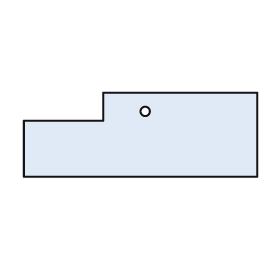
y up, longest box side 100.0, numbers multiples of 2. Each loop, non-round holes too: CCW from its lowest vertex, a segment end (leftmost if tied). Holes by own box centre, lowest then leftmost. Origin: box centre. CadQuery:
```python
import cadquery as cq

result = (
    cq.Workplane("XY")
    .moveTo(-50.0, -18.0)
    .lineTo(50.0, -18.0)
    .lineTo(50.0, 18.0)
    .lineTo(-16.0, 18.0)
    .lineTo(-16.0, 6.0)
    .lineTo(-50.0, 6.0)
    .close()
    .moveTo(2.0, 10.0)
    .circle(2.0)
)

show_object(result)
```